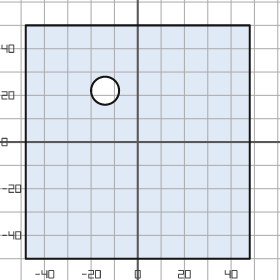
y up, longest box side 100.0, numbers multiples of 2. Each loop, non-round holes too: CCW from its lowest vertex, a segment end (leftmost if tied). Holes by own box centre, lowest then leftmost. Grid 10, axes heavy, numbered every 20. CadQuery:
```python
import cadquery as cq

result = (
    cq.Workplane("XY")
    .moveTo(-48.0, -50.0)
    .lineTo(48.0, -50.0)
    .lineTo(48.0, 50.0)
    .lineTo(-48.0, 50.0)
    .close()
    .moveTo(-14.0, 22.0)
    .circle(6.0)
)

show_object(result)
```